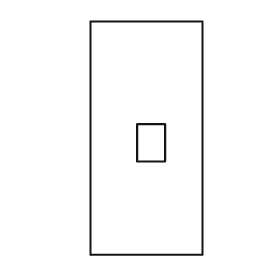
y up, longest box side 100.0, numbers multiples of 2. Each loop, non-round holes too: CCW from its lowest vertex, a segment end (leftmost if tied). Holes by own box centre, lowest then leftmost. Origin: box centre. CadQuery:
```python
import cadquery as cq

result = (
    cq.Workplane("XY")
    .moveTo(-24.0, -50.0)
    .lineTo(24.0, -50.0)
    .lineTo(24.0, 50.0)
    .lineTo(-24.0, 50.0)
    .close()
    .moveTo(-4.0, -10.0)
    .lineTo(8.0, -10.0)
    .lineTo(8.0, 6.0)
    .lineTo(-4.0, 6.0)
    .close()
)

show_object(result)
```